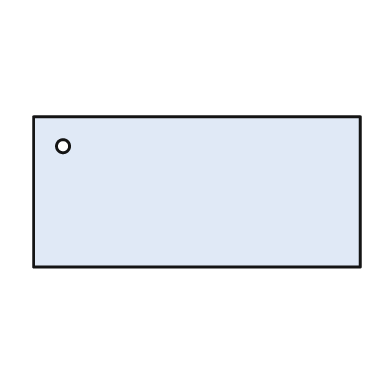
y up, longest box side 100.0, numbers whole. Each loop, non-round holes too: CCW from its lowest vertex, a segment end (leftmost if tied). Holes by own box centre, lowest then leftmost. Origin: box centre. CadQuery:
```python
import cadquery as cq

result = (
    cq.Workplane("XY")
    .moveTo(-50.0, -23.0)
    .lineTo(50.0, -23.0)
    .lineTo(50.0, 23.0)
    .lineTo(-50.0, 23.0)
    .close()
    .moveTo(-41.0, 14.0)
    .circle(2.0)
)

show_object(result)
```